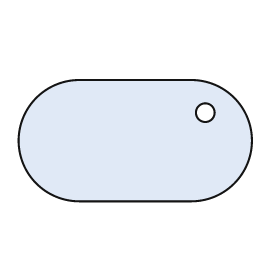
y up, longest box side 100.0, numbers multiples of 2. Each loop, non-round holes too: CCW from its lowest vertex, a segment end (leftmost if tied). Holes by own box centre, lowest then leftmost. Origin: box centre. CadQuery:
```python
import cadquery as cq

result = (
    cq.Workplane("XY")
    .moveTo(-24.0, -26.0)
    .lineTo(24.0, -26.0)
    .threePointArc((50.0, 0.0), (24.0, 26.0))
    .lineTo(-24.0, 26.0)
    .threePointArc((-50.0, 0.0), (-24.0, -26.0))
    .close()
    .moveTo(30.0, 12.0)
    .circle(4.0)
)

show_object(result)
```